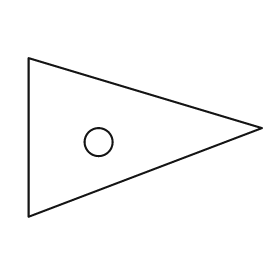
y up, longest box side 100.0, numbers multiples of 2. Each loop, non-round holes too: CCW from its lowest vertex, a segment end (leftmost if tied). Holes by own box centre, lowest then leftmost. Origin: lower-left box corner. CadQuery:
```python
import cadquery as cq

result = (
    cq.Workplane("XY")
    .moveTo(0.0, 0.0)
    .lineTo(100.0, 38.0)
    .lineTo(0.0, 68.0)
    .close()
    .moveTo(30.0, 32.0)
    .circle(6.0)
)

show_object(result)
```